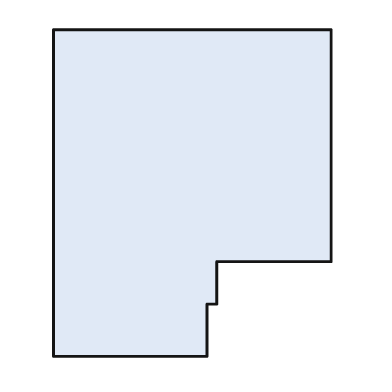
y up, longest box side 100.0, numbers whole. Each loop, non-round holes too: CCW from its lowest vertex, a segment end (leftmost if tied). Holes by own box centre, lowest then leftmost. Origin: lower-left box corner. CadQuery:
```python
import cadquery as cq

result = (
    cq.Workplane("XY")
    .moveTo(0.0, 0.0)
    .lineTo(47.0, 0.0)
    .lineTo(47.0, 16.0)
    .lineTo(50.0, 16.0)
    .lineTo(50.0, 29.0)
    .lineTo(85.0, 29.0)
    .lineTo(85.0, 100.0)
    .lineTo(0.0, 100.0)
    .close()
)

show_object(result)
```